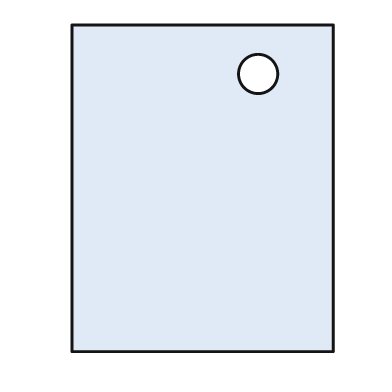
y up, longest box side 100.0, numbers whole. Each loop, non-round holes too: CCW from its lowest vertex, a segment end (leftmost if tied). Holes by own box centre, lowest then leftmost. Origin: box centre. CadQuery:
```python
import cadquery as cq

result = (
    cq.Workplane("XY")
    .moveTo(-40.0, -50.0)
    .lineTo(40.0, -50.0)
    .lineTo(40.0, 50.0)
    .lineTo(-40.0, 50.0)
    .close()
    .moveTo(17.0, 35.0)
    .circle(6.0)
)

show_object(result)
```